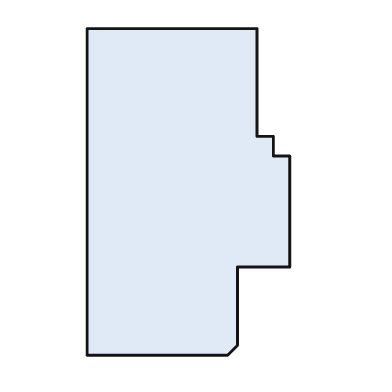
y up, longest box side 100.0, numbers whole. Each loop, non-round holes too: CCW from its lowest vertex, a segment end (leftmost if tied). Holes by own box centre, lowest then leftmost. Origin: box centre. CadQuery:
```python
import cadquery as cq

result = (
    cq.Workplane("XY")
    .moveTo(-31.0, -50.0)
    .lineTo(12.0, -50.0)
    .lineTo(15.0, -47.0)
    .lineTo(15.0, -23.0)
    .lineTo(31.0, -23.0)
    .lineTo(31.0, 11.0)
    .lineTo(26.0, 11.0)
    .lineTo(26.0, 17.0)
    .lineTo(21.0, 17.0)
    .lineTo(21.0, 50.0)
    .lineTo(-31.0, 50.0)
    .close()
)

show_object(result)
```